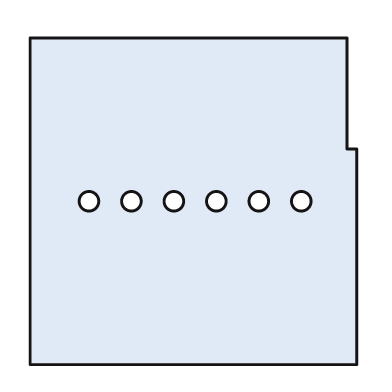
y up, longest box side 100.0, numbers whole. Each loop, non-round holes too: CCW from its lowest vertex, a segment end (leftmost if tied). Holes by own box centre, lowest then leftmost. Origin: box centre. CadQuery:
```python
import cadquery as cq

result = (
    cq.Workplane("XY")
    .moveTo(-50.0, -50.0)
    .lineTo(50.0, -50.0)
    .lineTo(50.0, 16.0)
    .lineTo(47.0, 16.0)
    .lineTo(47.0, 50.0)
    .lineTo(-50.0, 50.0)
    .close()
    .moveTo(-32.0, 0.0)
    .circle(3.0)
    .moveTo(-19.0, 0.0)
    .circle(3.0)
    .moveTo(-6.0, 0.0)
    .circle(3.0)
    .moveTo(7.0, 0.0)
    .circle(3.0)
    .moveTo(20.0, 0.0)
    .circle(3.0)
    .moveTo(33.0, 0.0)
    .circle(3.0)
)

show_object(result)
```